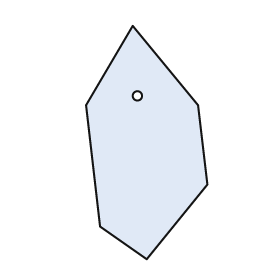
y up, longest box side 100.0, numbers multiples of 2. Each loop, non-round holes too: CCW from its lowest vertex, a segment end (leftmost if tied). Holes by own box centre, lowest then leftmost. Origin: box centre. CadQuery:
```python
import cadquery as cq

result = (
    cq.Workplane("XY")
    .moveTo(0.0, -50.0)
    .lineTo(26.0, -18.0)
    .lineTo(22.0, 16.0)
    .lineTo(-6.0, 50.0)
    .lineTo(-26.0, 16.0)
    .lineTo(-20.0, -36.0)
    .close()
    .moveTo(-4.0, 20.0)
    .circle(2.0)
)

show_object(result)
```